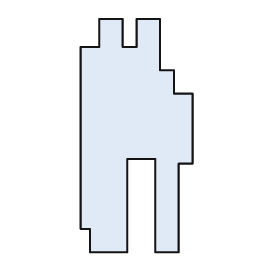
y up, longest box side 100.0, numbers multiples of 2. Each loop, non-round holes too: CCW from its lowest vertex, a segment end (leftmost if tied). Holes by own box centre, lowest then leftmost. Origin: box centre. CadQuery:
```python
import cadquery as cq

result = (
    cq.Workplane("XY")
    .moveTo(-20.0, -50.0)
    .lineTo(-4.0, -50.0)
    .lineTo(-4.0, -10.0)
    .lineTo(8.0, -10.0)
    .lineTo(8.0, -50.0)
    .lineTo(18.0, -50.0)
    .lineTo(18.0, -12.0)
    .lineTo(24.0, -12.0)
    .lineTo(24.0, 18.0)
    .lineTo(16.0, 18.0)
    .lineTo(16.0, 28.0)
    .lineTo(10.0, 28.0)
    .lineTo(10.0, 50.0)
    .lineTo(0.0, 50.0)
    .lineTo(0.0, 38.0)
    .lineTo(-6.0, 38.0)
    .lineTo(-6.0, 50.0)
    .lineTo(-16.0, 50.0)
    .lineTo(-16.0, 38.0)
    .lineTo(-24.0, 38.0)
    .lineTo(-24.0, -40.0)
    .lineTo(-20.0, -40.0)
    .close()
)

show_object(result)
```